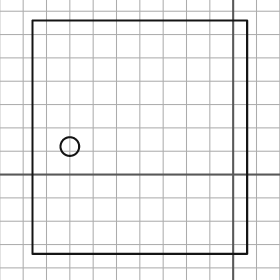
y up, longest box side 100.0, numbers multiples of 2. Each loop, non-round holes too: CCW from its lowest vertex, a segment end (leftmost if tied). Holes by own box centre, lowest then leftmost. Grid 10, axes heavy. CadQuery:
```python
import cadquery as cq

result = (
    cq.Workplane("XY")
    .moveTo(-86.0, -34.0)
    .lineTo(6.0, -34.0)
    .lineTo(6.0, 66.0)
    .lineTo(-86.0, 66.0)
    .close()
    .moveTo(-70.0, 12.0)
    .circle(4.0)
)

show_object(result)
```